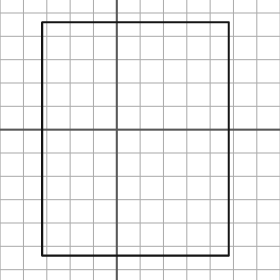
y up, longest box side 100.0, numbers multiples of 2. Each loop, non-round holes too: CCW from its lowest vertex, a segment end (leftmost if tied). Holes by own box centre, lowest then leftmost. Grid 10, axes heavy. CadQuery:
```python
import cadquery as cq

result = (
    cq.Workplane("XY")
    .moveTo(-32.0, -54.0)
    .lineTo(48.0, -54.0)
    .lineTo(48.0, 46.0)
    .lineTo(-32.0, 46.0)
    .close()
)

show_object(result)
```